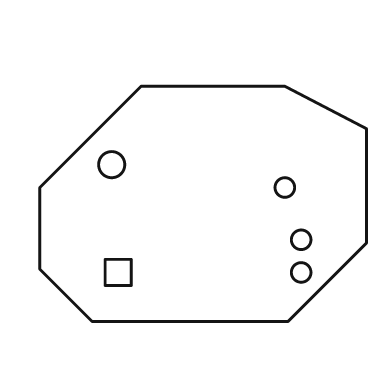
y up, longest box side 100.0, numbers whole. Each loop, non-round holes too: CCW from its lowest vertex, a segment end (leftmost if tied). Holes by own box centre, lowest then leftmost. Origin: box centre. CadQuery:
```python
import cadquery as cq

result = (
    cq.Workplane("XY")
    .moveTo(-34.0, -36.0)
    .lineTo(26.0, -36.0)
    .lineTo(50.0, -12.0)
    .lineTo(50.0, 23.0)
    .lineTo(25.0, 36.0)
    .lineTo(-19.0, 36.0)
    .lineTo(-50.0, 5.0)
    .lineTo(-50.0, -20.0)
    .close()
    .moveTo(-30.0, -25.0)
    .lineTo(-22.0, -25.0)
    .lineTo(-22.0, -17.0)
    .lineTo(-30.0, -17.0)
    .close()
    .moveTo(30.0, -21.0)
    .circle(3.0)
    .moveTo(30.0, -11.0)
    .circle(3.0)
    .moveTo(25.0, 5.0)
    .circle(3.0)
    .moveTo(-28.0, 12.0)
    .circle(4.0)
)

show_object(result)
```